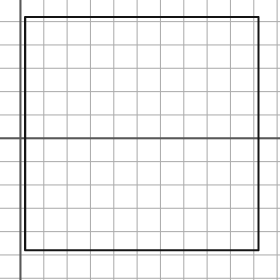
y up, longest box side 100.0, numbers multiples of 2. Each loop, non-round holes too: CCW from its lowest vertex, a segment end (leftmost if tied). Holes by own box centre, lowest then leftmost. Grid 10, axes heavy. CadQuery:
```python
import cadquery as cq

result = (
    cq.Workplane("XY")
    .moveTo(2.0, -48.0)
    .lineTo(102.0, -48.0)
    .lineTo(102.0, 52.0)
    .lineTo(2.0, 52.0)
    .close()
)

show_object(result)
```